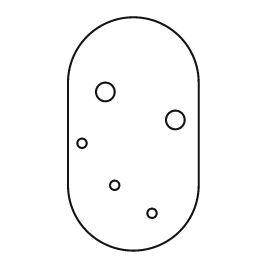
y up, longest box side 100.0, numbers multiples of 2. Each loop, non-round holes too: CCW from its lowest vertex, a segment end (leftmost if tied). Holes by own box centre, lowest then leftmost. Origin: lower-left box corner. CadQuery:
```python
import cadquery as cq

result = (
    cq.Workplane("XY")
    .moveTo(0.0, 28.0)
    .threePointArc((28.0, 0.0), (56.0, 28.0))
    .lineTo(56.0, 72.0)
    .threePointArc((28.0, 100.0), (0.0, 72.0))
    .close()
    .moveTo(36.0, 16.0)
    .circle(2.0)
    .moveTo(20.0, 28.0)
    .circle(2.0)
    .moveTo(6.0, 46.0)
    .circle(2.0)
    .moveTo(46.0, 56.0)
    .circle(4.0)
    .moveTo(16.0, 68.0)
    .circle(4.0)
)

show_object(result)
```